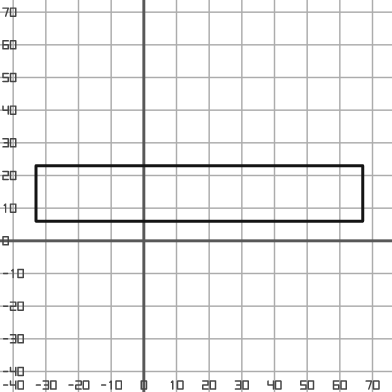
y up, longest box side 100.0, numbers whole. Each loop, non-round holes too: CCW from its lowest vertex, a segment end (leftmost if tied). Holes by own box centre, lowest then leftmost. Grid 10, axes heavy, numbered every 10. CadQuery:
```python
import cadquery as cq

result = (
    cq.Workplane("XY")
    .moveTo(-33.0, 6.0)
    .lineTo(67.0, 6.0)
    .lineTo(67.0, 23.0)
    .lineTo(-33.0, 23.0)
    .close()
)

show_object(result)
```